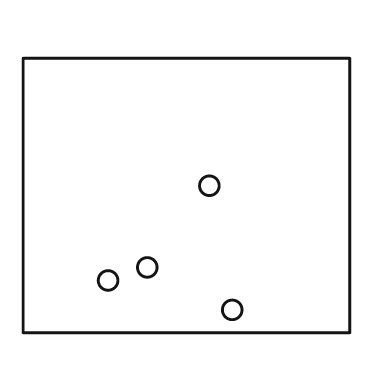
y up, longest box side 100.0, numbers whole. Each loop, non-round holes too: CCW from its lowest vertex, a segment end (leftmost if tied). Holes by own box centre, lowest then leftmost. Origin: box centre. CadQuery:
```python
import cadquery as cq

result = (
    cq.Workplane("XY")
    .moveTo(-50.0, -42.0)
    .lineTo(50.0, -42.0)
    .lineTo(50.0, 42.0)
    .lineTo(-50.0, 42.0)
    .close()
    .moveTo(14.0, -35.0)
    .circle(3.0)
    .moveTo(-24.0, -26.0)
    .circle(3.0)
    .moveTo(-12.0, -22.0)
    .circle(3.0)
    .moveTo(7.0, 3.0)
    .circle(3.0)
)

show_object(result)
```